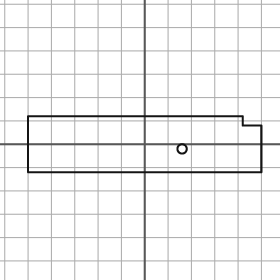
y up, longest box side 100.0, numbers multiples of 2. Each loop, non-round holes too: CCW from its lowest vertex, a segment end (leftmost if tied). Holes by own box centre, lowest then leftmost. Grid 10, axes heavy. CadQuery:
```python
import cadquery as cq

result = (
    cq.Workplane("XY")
    .moveTo(-50.0, -12.0)
    .lineTo(50.0, -12.0)
    .lineTo(50.0, 8.0)
    .lineTo(42.0, 8.0)
    .lineTo(42.0, 12.0)
    .lineTo(-50.0, 12.0)
    .close()
    .moveTo(16.0, -2.0)
    .circle(2.0)
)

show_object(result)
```